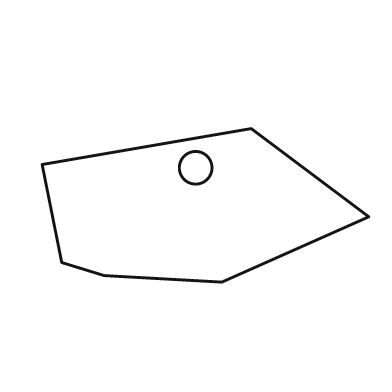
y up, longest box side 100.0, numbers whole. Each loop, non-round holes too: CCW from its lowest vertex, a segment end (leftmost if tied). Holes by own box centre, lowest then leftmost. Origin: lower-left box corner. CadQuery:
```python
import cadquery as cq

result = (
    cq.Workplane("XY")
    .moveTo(55.0, 0.0)
    .lineTo(100.0, 20.0)
    .lineTo(64.0, 47.0)
    .lineTo(0.0, 36.0)
    .lineTo(6.0, 6.0)
    .lineTo(19.0, 2.0)
    .close()
    .moveTo(47.0, 35.0)
    .circle(5.0)
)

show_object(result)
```